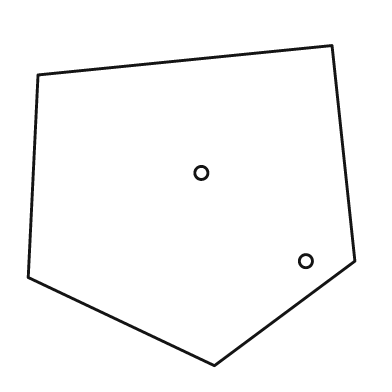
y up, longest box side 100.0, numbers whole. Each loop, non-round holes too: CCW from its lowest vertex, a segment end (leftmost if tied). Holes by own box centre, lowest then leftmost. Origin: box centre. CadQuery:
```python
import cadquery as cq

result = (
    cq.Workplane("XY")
    .moveTo(7.0, -49.0)
    .lineTo(50.0, -17.0)
    .lineTo(43.0, 49.0)
    .lineTo(-47.0, 40.0)
    .lineTo(-50.0, -22.0)
    .close()
    .moveTo(35.0, -17.0)
    .circle(2.0)
    .moveTo(3.0, 10.0)
    .circle(2.0)
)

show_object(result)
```